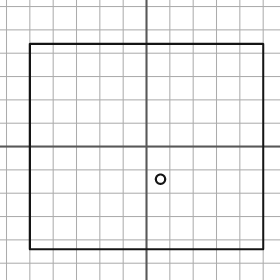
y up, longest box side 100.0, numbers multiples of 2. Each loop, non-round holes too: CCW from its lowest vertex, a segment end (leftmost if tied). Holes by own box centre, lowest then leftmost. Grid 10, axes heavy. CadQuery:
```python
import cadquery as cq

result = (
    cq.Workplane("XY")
    .moveTo(-50.0, -44.0)
    .lineTo(50.0, -44.0)
    .lineTo(50.0, 44.0)
    .lineTo(-50.0, 44.0)
    .close()
    .moveTo(6.0, -14.0)
    .circle(2.0)
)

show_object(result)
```